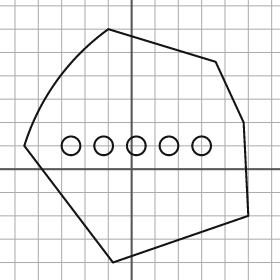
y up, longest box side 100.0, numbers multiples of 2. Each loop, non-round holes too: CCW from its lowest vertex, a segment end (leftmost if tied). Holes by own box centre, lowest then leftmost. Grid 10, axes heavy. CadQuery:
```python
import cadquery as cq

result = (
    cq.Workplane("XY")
    .moveTo(-8.0, -40.0)
    .lineTo(50.0, -20.0)
    .lineTo(48.0, 20.0)
    .lineTo(36.0, 46.0)
    .lineTo(-10.0, 60.0)
    .threePointArc((-32.0, 38.0), (-46.0, 10.0))
    .close()
    .moveTo(-26.0, 10.0)
    .circle(4.0)
    .moveTo(-12.0, 10.0)
    .circle(4.0)
    .moveTo(2.0, 10.0)
    .circle(4.0)
    .moveTo(16.0, 10.0)
    .circle(4.0)
    .moveTo(30.0, 10.0)
    .circle(4.0)
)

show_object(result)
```